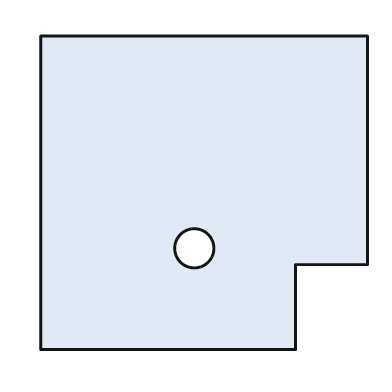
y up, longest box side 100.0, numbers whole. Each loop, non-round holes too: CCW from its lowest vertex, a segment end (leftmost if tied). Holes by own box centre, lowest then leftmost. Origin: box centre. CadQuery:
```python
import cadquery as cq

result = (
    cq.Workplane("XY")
    .moveTo(-50.0, -48.0)
    .lineTo(28.0, -48.0)
    .lineTo(28.0, -22.0)
    .lineTo(50.0, -22.0)
    .lineTo(50.0, 48.0)
    .lineTo(-50.0, 48.0)
    .close()
    .moveTo(-3.0, -17.0)
    .circle(6.0)
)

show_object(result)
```